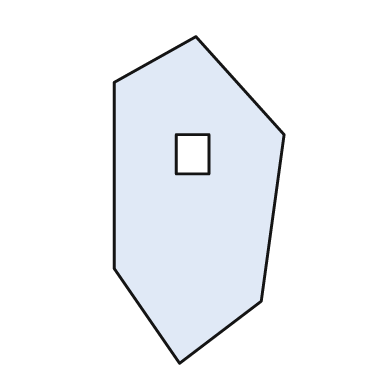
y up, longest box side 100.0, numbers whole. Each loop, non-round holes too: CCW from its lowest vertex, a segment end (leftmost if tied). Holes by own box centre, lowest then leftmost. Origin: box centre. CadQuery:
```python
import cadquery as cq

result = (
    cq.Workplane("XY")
    .moveTo(-6.0, -50.0)
    .lineTo(19.0, -31.0)
    .lineTo(26.0, 20.0)
    .lineTo(-1.0, 50.0)
    .lineTo(-26.0, 36.0)
    .lineTo(-26.0, -21.0)
    .close()
    .moveTo(-7.0, 8.0)
    .lineTo(3.0, 8.0)
    .lineTo(3.0, 20.0)
    .lineTo(-7.0, 20.0)
    .close()
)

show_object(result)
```